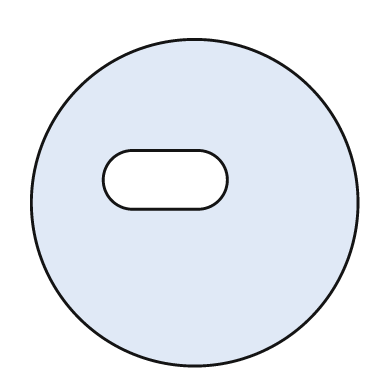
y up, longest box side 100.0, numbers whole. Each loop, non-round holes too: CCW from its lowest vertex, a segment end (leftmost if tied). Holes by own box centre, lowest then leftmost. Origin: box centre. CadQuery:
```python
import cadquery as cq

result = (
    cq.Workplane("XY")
    .moveTo(0.0, 0.0)
    .circle(50.0)
    .moveTo(-19.0, -2.0)
    .lineTo(1.0, -2.0)
    .threePointArc((10.0, 7.0), (1.0, 16.0))
    .lineTo(-19.0, 16.0)
    .threePointArc((-28.0, 7.0), (-19.0, -2.0))
    .close()
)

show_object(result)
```